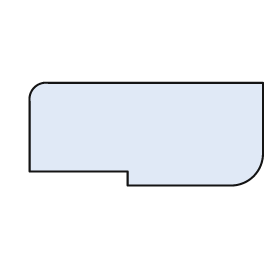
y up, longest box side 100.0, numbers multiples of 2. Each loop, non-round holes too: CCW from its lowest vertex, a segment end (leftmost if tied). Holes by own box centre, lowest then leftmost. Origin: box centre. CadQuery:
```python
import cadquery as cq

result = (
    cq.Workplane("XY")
    .moveTo(-8.0, -22.0)
    .lineTo(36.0, -22.0)
    .threePointArc((46.0, -18.0), (50.0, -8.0))
    .lineTo(50.0, 22.0)
    .lineTo(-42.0, 22.0)
    .threePointArc((-48.0, 20.0), (-50.0, 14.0))
    .lineTo(-50.0, -16.0)
    .lineTo(-8.0, -16.0)
    .close()
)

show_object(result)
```